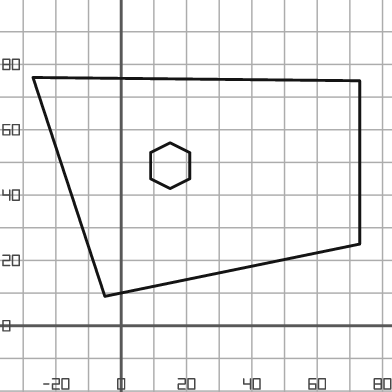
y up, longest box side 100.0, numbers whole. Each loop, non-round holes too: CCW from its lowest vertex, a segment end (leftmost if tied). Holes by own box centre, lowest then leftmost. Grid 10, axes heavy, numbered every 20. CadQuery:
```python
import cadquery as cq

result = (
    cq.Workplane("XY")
    .moveTo(-5.0, 9.0)
    .lineTo(73.0, 25.0)
    .lineTo(73.0, 75.0)
    .lineTo(-27.0, 76.0)
    .close()
    .moveTo(15.0, 42.0)
    .lineTo(21.0, 45.0)
    .lineTo(21.0, 53.0)
    .lineTo(15.0, 56.0)
    .lineTo(9.0, 53.0)
    .lineTo(9.0, 45.0)
    .close()
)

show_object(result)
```